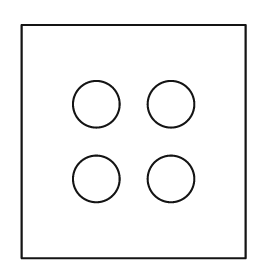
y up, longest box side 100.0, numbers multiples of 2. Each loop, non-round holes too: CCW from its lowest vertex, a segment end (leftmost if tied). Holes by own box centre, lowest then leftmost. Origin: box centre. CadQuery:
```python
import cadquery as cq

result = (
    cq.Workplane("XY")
    .moveTo(-48.0, -50.0)
    .lineTo(48.0, -50.0)
    .lineTo(48.0, 50.0)
    .lineTo(-48.0, 50.0)
    .close()
    .moveTo(-16.0, -16.0)
    .circle(10.0)
    .moveTo(16.0, -16.0)
    .circle(10.0)
    .moveTo(-16.0, 16.0)
    .circle(10.0)
    .moveTo(16.0, 16.0)
    .circle(10.0)
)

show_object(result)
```